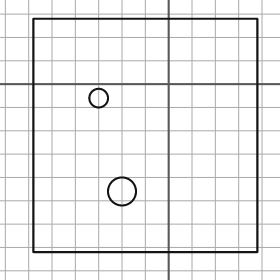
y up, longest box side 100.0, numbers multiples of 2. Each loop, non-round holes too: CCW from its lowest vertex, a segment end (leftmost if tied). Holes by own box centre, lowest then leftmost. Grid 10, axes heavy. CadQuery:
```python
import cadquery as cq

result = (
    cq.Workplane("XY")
    .moveTo(-58.0, -72.0)
    .lineTo(38.0, -72.0)
    .lineTo(38.0, 28.0)
    .lineTo(-58.0, 28.0)
    .close()
    .moveTo(-20.0, -46.0)
    .circle(6.0)
    .moveTo(-30.0, -6.0)
    .circle(4.0)
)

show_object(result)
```